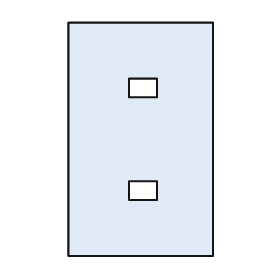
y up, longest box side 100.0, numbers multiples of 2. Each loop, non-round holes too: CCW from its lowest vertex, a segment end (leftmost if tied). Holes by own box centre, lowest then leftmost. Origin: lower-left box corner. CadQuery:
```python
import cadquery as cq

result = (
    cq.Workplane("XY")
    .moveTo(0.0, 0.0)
    .lineTo(62.0, 0.0)
    .lineTo(62.0, 100.0)
    .lineTo(0.0, 100.0)
    .close()
    .moveTo(26.0, 24.0)
    .lineTo(38.0, 24.0)
    .lineTo(38.0, 32.0)
    .lineTo(26.0, 32.0)
    .close()
    .moveTo(26.0, 68.0)
    .lineTo(38.0, 68.0)
    .lineTo(38.0, 76.0)
    .lineTo(26.0, 76.0)
    .close()
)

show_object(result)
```